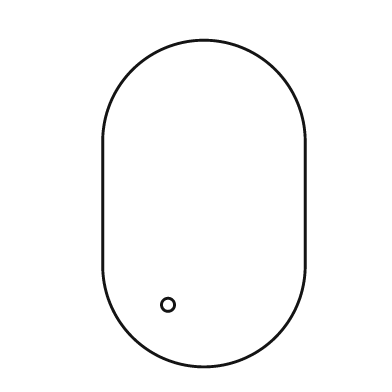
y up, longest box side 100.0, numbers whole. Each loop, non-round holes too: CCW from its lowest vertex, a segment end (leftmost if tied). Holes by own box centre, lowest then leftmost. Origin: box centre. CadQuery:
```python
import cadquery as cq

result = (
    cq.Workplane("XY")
    .moveTo(-31.0, -19.0)
    .threePointArc((0.0, -50.0), (31.0, -19.0))
    .lineTo(31.0, 19.0)
    .threePointArc((0.0, 50.0), (-31.0, 19.0))
    .close()
    .moveTo(-11.0, -31.0)
    .circle(2.0)
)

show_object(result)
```